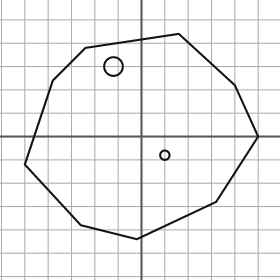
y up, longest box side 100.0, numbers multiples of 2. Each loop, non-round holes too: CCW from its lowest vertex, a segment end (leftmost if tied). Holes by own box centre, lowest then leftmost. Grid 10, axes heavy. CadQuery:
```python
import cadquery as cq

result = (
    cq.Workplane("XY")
    .moveTo(-2.0, -44.0)
    .lineTo(32.0, -28.0)
    .lineTo(50.0, 0.0)
    .lineTo(40.0, 22.0)
    .lineTo(16.0, 44.0)
    .lineTo(-24.0, 38.0)
    .lineTo(-38.0, 24.0)
    .lineTo(-50.0, -12.0)
    .lineTo(-26.0, -38.0)
    .close()
    .moveTo(10.0, -8.0)
    .circle(2.0)
    .moveTo(-12.0, 30.0)
    .circle(4.0)
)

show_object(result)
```